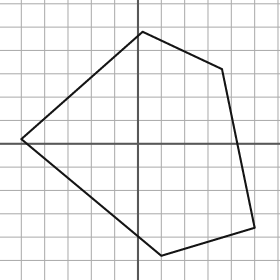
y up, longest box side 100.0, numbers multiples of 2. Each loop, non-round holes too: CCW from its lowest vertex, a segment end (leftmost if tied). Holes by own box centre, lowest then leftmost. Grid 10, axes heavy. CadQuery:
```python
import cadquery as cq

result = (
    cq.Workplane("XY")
    .moveTo(10.0, -48.0)
    .lineTo(50.0, -36.0)
    .lineTo(36.0, 32.0)
    .lineTo(2.0, 48.0)
    .lineTo(-50.0, 2.0)
    .close()
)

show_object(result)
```